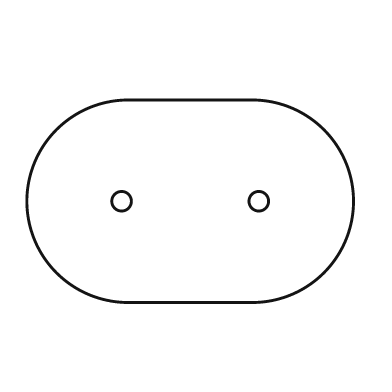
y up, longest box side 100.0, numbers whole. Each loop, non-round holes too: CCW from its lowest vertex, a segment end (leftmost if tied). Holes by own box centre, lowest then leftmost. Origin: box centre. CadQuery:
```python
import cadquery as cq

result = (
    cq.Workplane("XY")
    .moveTo(-19.0, -31.0)
    .lineTo(19.0, -31.0)
    .threePointArc((50.0, 0.0), (19.0, 31.0))
    .lineTo(-19.0, 31.0)
    .threePointArc((-50.0, 0.0), (-19.0, -31.0))
    .close()
    .moveTo(-21.0, 0.0)
    .circle(3.0)
    .moveTo(21.0, 0.0)
    .circle(3.0)
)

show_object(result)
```